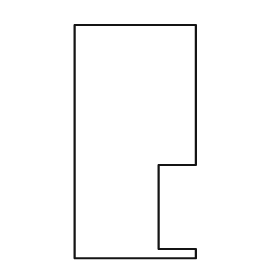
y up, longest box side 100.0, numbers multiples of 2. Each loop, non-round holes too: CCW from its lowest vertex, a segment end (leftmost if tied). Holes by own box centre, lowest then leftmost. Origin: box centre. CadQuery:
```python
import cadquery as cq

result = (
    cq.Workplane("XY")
    .moveTo(-26.0, -50.0)
    .lineTo(26.0, -50.0)
    .lineTo(26.0, -46.0)
    .lineTo(10.0, -46.0)
    .lineTo(10.0, -10.0)
    .lineTo(26.0, -10.0)
    .lineTo(26.0, 50.0)
    .lineTo(-26.0, 50.0)
    .close()
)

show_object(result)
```